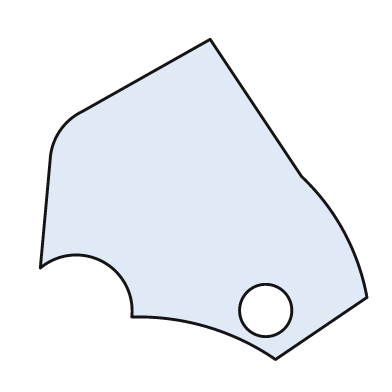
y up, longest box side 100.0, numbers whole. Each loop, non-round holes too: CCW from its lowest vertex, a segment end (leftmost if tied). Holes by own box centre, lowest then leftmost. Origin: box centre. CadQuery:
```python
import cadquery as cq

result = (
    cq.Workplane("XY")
    .moveTo(22.0, -49.0)
    .lineTo(50.0, -30.0)
    .threePointArc((43.0, -10.0), (30.0, 7.0))
    .lineTo(2.0, 49.0)
    .lineTo(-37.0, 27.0)
    .threePointArc((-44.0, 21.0), (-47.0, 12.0))
    .lineTo(-50.0, -21.0)
    .threePointArc((-31.0, -19.0), (-22.0, -36.0))
    .threePointArc((1.0, -39.0), (22.0, -49.0))
    .close()
    .moveTo(19.0, -34.0)
    .circle(8.0)
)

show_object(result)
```